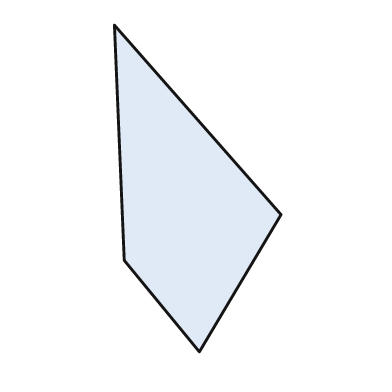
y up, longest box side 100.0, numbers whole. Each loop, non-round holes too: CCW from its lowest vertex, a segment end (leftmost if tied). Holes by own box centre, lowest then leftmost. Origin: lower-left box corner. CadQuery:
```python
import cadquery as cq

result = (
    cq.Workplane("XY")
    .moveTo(26.0, 0.0)
    .lineTo(51.0, 42.0)
    .lineTo(0.0, 100.0)
    .lineTo(3.0, 28.0)
    .close()
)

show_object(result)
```